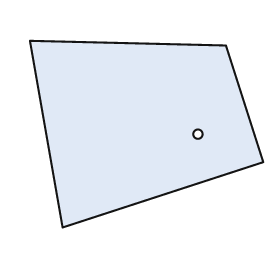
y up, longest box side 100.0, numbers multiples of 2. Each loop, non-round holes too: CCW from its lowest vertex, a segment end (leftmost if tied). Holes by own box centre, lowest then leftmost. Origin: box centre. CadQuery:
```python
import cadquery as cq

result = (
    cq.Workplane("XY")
    .moveTo(-36.0, -40.0)
    .lineTo(50.0, -12.0)
    .lineTo(34.0, 38.0)
    .lineTo(-50.0, 40.0)
    .close()
    .moveTo(22.0, 0.0)
    .circle(2.0)
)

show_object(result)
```